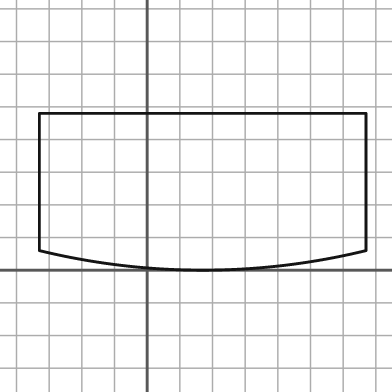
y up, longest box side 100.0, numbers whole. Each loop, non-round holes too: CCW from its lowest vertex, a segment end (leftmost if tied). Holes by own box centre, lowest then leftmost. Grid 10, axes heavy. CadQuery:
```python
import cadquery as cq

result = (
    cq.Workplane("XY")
    .moveTo(-33.0, 6.0)
    .threePointArc((17.0, 0.0), (67.0, 6.0))
    .lineTo(67.0, 48.0)
    .lineTo(-33.0, 48.0)
    .close()
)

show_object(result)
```